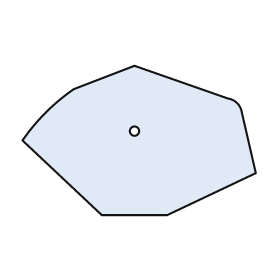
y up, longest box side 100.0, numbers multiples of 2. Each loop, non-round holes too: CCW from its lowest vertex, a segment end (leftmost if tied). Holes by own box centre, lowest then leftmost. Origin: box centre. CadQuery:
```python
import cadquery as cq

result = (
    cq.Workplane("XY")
    .moveTo(-16.0, -32.0)
    .lineTo(12.0, -32.0)
    .lineTo(50.0, -14.0)
    .lineTo(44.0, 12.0)
    .threePointArc((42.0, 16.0), (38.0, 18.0))
    .lineTo(-2.0, 32.0)
    .lineTo(-28.0, 22.0)
    .threePointArc((-40.0, 12.0), (-50.0, 0.0))
    .close()
    .moveTo(-2.0, 4.0)
    .circle(2.0)
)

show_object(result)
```